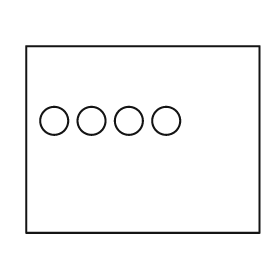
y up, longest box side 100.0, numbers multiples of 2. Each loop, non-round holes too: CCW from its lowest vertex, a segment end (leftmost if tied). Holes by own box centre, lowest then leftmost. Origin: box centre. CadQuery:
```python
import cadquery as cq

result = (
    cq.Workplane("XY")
    .moveTo(-50.0, -40.0)
    .lineTo(50.0, -40.0)
    .lineTo(50.0, 40.0)
    .lineTo(-50.0, 40.0)
    .close()
    .moveTo(-38.0, 8.0)
    .circle(6.0)
    .moveTo(-22.0, 8.0)
    .circle(6.0)
    .moveTo(-6.0, 8.0)
    .circle(6.0)
    .moveTo(10.0, 8.0)
    .circle(6.0)
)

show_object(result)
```